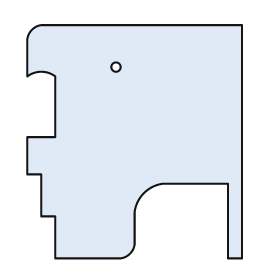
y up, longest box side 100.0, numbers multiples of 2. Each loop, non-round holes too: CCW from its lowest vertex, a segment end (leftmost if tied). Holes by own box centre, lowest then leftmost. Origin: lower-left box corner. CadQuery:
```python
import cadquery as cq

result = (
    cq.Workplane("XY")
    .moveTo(12.0, 0.0)
    .lineTo(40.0, 0.0)
    .threePointArc((44.0, 2.0), (46.0, 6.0))
    .lineTo(46.0, 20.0)
    .threePointArc((50.0, 28.0), (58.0, 32.0))
    .lineTo(86.0, 32.0)
    .lineTo(86.0, 0.0)
    .lineTo(92.0, 0.0)
    .lineTo(92.0, 100.0)
    .lineTo(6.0, 100.0)
    .threePointArc((2.0, 98.0), (0.0, 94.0))
    .lineTo(0.0, 78.0)
    .threePointArc((6.0, 80.0), (12.0, 78.0))
    .lineTo(12.0, 52.0)
    .lineTo(0.0, 52.0)
    .lineTo(0.0, 36.0)
    .lineTo(6.0, 36.0)
    .lineTo(6.0, 18.0)
    .lineTo(12.0, 18.0)
    .close()
    .moveTo(38.0, 82.0)
    .circle(2.0)
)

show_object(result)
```